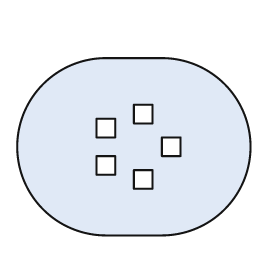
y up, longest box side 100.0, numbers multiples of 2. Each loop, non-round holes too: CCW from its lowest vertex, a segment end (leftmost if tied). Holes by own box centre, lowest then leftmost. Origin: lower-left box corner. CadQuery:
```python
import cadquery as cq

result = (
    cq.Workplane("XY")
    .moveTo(38.0, 0.0)
    .lineTo(62.0, 0.0)
    .threePointArc((100.0, 38.0), (62.0, 76.0))
    .lineTo(38.0, 76.0)
    .threePointArc((0.0, 38.0), (38.0, 0.0))
    .close()
    .moveTo(50.0, 20.0)
    .lineTo(58.0, 20.0)
    .lineTo(58.0, 28.0)
    .lineTo(50.0, 28.0)
    .close()
    .moveTo(34.0, 26.0)
    .lineTo(42.0, 26.0)
    .lineTo(42.0, 34.0)
    .lineTo(34.0, 34.0)
    .close()
    .moveTo(62.0, 34.0)
    .lineTo(70.0, 34.0)
    .lineTo(70.0, 42.0)
    .lineTo(62.0, 42.0)
    .close()
    .moveTo(34.0, 42.0)
    .lineTo(42.0, 42.0)
    .lineTo(42.0, 50.0)
    .lineTo(34.0, 50.0)
    .close()
    .moveTo(50.0, 48.0)
    .lineTo(58.0, 48.0)
    .lineTo(58.0, 56.0)
    .lineTo(50.0, 56.0)
    .close()
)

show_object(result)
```